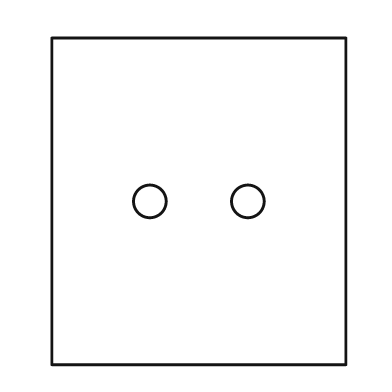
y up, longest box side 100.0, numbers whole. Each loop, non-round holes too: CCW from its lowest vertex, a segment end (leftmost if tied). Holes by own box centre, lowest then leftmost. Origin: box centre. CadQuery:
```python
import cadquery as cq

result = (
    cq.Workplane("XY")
    .moveTo(-45.0, -50.0)
    .lineTo(45.0, -50.0)
    .lineTo(45.0, 50.0)
    .lineTo(-45.0, 50.0)
    .close()
    .moveTo(-15.0, 0.0)
    .circle(5.0)
    .moveTo(15.0, 0.0)
    .circle(5.0)
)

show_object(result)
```